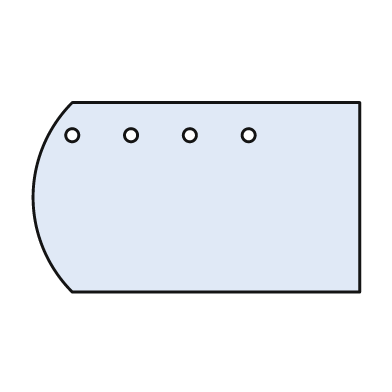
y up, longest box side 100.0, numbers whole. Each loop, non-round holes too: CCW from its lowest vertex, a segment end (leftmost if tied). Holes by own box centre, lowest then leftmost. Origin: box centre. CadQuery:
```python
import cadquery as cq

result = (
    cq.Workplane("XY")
    .moveTo(-38.0, -29.0)
    .lineTo(50.0, -29.0)
    .lineTo(50.0, 29.0)
    .lineTo(-38.0, 29.0)
    .threePointArc((-50.0, 0.0), (-38.0, -29.0))
    .close()
    .moveTo(-38.0, 19.0)
    .circle(2.0)
    .moveTo(-20.0, 19.0)
    .circle(2.0)
    .moveTo(-2.0, 19.0)
    .circle(2.0)
    .moveTo(16.0, 19.0)
    .circle(2.0)
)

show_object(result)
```